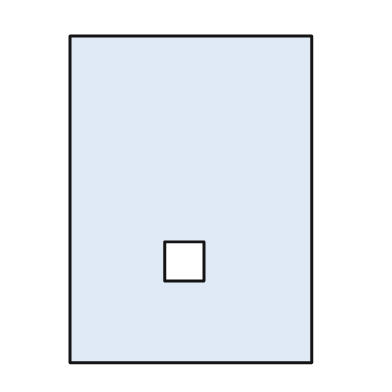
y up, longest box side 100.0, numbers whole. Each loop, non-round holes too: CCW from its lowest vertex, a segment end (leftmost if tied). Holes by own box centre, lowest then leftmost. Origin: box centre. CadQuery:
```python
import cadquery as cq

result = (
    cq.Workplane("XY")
    .moveTo(-37.0, -50.0)
    .lineTo(37.0, -50.0)
    .lineTo(37.0, 50.0)
    .lineTo(-37.0, 50.0)
    .close()
    .moveTo(-8.0, -25.0)
    .lineTo(4.0, -25.0)
    .lineTo(4.0, -13.0)
    .lineTo(-8.0, -13.0)
    .close()
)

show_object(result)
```